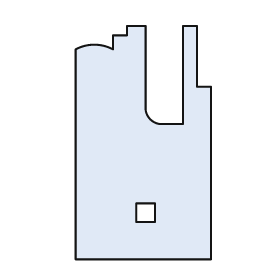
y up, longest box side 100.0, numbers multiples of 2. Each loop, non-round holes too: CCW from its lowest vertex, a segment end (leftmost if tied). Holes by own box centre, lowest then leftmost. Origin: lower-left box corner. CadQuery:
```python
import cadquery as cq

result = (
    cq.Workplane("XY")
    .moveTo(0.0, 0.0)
    .lineTo(58.0, 0.0)
    .lineTo(58.0, 74.0)
    .lineTo(52.0, 74.0)
    .lineTo(52.0, 100.0)
    .lineTo(46.0, 100.0)
    .lineTo(46.0, 58.0)
    .lineTo(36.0, 58.0)
    .threePointArc((32.0, 60.0), (30.0, 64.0))
    .lineTo(30.0, 100.0)
    .lineTo(22.0, 100.0)
    .lineTo(22.0, 96.0)
    .lineTo(16.0, 96.0)
    .lineTo(16.0, 90.0)
    .threePointArc((8.0, 92.0), (0.0, 90.0))
    .close()
    .moveTo(26.0, 16.0)
    .lineTo(34.0, 16.0)
    .lineTo(34.0, 24.0)
    .lineTo(26.0, 24.0)
    .close()
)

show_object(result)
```